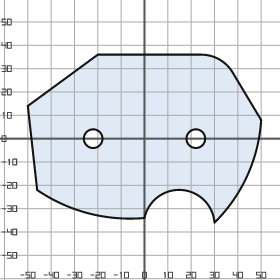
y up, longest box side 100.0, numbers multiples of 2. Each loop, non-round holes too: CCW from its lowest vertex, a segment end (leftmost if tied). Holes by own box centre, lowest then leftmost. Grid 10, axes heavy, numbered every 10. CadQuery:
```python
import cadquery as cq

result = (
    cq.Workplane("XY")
    .moveTo(30.0, -36.0)
    .threePointArc((44.0, -16.0), (50.0, 8.0))
    .lineTo(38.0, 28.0)
    .threePointArc((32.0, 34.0), (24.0, 36.0))
    .lineTo(-20.0, 36.0)
    .lineTo(-50.0, 14.0)
    .lineTo(-46.0, -22.0)
    .threePointArc((-24.0, -32.0), (0.0, -34.0))
    .threePointArc((16.0, -22.0), (30.0, -36.0))
    .close()
    .moveTo(-22.0, 0.0)
    .circle(4.0)
    .moveTo(22.0, 0.0)
    .circle(4.0)
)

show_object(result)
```